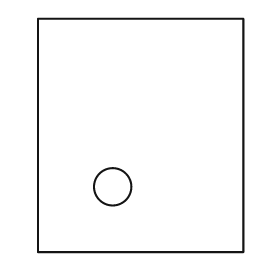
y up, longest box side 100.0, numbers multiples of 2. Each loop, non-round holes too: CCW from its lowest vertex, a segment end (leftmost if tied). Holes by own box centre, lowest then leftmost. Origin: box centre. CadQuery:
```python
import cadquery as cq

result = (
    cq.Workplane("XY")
    .moveTo(-44.0, -50.0)
    .lineTo(44.0, -50.0)
    .lineTo(44.0, 50.0)
    .lineTo(-44.0, 50.0)
    .close()
    .moveTo(-12.0, -22.0)
    .circle(8.0)
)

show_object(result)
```